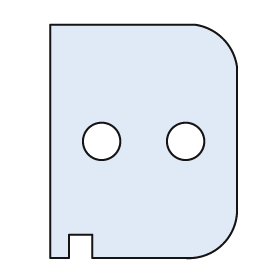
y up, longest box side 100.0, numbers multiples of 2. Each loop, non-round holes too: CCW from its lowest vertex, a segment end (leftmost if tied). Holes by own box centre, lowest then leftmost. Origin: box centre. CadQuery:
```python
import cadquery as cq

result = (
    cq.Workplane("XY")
    .moveTo(-40.0, -50.0)
    .lineTo(-32.0, -50.0)
    .lineTo(-32.0, -40.0)
    .lineTo(-22.0, -40.0)
    .lineTo(-22.0, -50.0)
    .lineTo(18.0, -50.0)
    .threePointArc((34.0, -44.0), (40.0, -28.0))
    .lineTo(40.0, 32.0)
    .threePointArc((34.0, 44.0), (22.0, 50.0))
    .lineTo(-40.0, 50.0)
    .close()
    .moveTo(-18.0, 0.0)
    .circle(8.0)
    .moveTo(18.0, 0.0)
    .circle(8.0)
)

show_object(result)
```